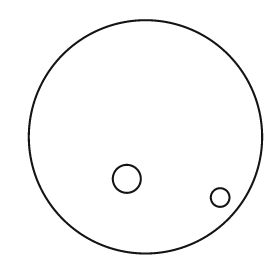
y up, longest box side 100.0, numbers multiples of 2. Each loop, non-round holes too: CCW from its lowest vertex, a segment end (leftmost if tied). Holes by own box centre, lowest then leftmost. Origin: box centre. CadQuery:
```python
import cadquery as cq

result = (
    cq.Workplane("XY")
    .moveTo(0.0, 0.0)
    .circle(50.0)
    .moveTo(32.0, -26.0)
    .circle(4.0)
    .moveTo(-8.0, -18.0)
    .circle(6.0)
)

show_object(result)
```